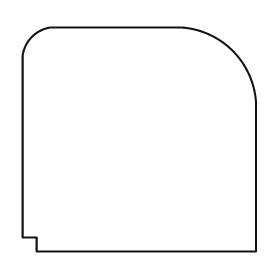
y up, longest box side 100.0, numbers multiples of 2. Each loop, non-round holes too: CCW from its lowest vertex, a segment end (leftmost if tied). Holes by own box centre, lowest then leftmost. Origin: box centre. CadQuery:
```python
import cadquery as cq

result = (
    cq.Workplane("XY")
    .moveTo(-44.0, -48.0)
    .lineTo(50.0, -48.0)
    .lineTo(50.0, 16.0)
    .threePointArc((40.0, 38.0), (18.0, 48.0))
    .lineTo(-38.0, 48.0)
    .threePointArc((-46.0, 44.0), (-50.0, 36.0))
    .lineTo(-50.0, -42.0)
    .lineTo(-44.0, -42.0)
    .close()
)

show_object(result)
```